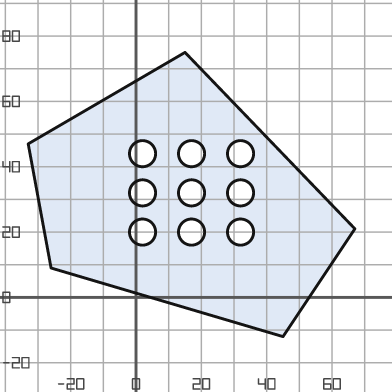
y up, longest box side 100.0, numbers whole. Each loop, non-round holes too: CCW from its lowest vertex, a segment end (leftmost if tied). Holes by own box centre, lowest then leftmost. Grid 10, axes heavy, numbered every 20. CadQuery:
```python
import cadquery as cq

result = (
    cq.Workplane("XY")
    .moveTo(45.0, -12.0)
    .lineTo(67.0, 21.0)
    .lineTo(15.0, 75.0)
    .lineTo(-33.0, 47.0)
    .lineTo(-26.0, 9.0)
    .close()
    .moveTo(2.0, 20.0)
    .circle(4.0)
    .moveTo(17.0, 20.0)
    .circle(4.0)
    .moveTo(32.0, 20.0)
    .circle(4.0)
    .moveTo(2.0, 32.0)
    .circle(4.0)
    .moveTo(17.0, 32.0)
    .circle(4.0)
    .moveTo(32.0, 32.0)
    .circle(4.0)
    .moveTo(2.0, 44.0)
    .circle(4.0)
    .moveTo(17.0, 44.0)
    .circle(4.0)
    .moveTo(32.0, 44.0)
    .circle(4.0)
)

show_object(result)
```